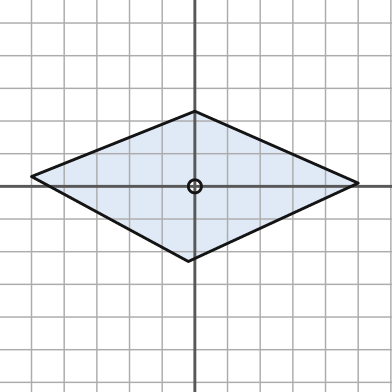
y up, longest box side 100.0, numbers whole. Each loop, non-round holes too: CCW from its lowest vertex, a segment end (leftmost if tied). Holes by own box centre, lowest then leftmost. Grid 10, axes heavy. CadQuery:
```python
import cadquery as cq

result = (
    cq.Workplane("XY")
    .moveTo(-2.0, -23.0)
    .lineTo(50.0, 1.0)
    .lineTo(0.0, 23.0)
    .lineTo(-50.0, 3.0)
    .close()
    .moveTo(0.0, 0.0)
    .circle(2.0)
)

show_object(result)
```